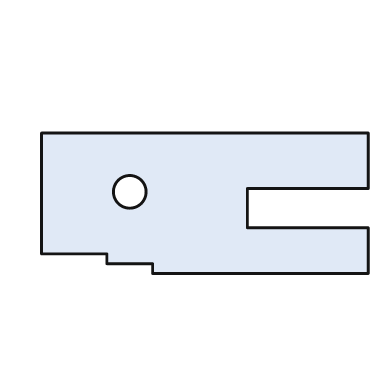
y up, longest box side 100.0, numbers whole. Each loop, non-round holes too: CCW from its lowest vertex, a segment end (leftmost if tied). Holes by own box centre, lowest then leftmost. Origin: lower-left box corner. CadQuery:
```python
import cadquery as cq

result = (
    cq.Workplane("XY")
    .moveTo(34.0, 0.0)
    .lineTo(100.0, 0.0)
    .lineTo(100.0, 14.0)
    .lineTo(63.0, 14.0)
    .lineTo(63.0, 26.0)
    .lineTo(100.0, 26.0)
    .lineTo(100.0, 43.0)
    .lineTo(0.0, 43.0)
    .lineTo(0.0, 6.0)
    .lineTo(20.0, 6.0)
    .lineTo(20.0, 3.0)
    .lineTo(34.0, 3.0)
    .close()
    .moveTo(27.0, 25.0)
    .circle(5.0)
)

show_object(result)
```